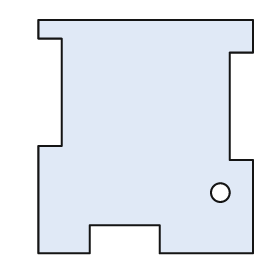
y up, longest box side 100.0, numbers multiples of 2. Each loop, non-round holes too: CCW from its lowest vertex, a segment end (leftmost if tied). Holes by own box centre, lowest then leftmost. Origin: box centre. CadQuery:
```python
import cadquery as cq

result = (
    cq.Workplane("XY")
    .moveTo(-46.0, -50.0)
    .lineTo(-24.0, -50.0)
    .lineTo(-24.0, -38.0)
    .lineTo(6.0, -38.0)
    .lineTo(6.0, -50.0)
    .lineTo(46.0, -50.0)
    .lineTo(46.0, -10.0)
    .lineTo(36.0, -10.0)
    .lineTo(36.0, 36.0)
    .lineTo(46.0, 36.0)
    .lineTo(46.0, 50.0)
    .lineTo(-46.0, 50.0)
    .lineTo(-46.0, 42.0)
    .lineTo(-36.0, 42.0)
    .lineTo(-36.0, -4.0)
    .lineTo(-46.0, -4.0)
    .close()
    .moveTo(32.0, -24.0)
    .circle(4.0)
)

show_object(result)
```